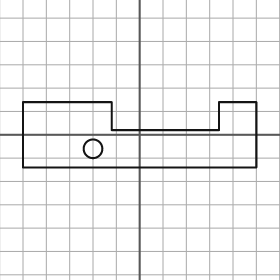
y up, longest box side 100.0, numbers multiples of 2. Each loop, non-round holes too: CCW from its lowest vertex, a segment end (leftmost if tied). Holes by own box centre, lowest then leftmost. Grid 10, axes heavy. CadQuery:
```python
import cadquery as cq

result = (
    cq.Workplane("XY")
    .moveTo(-50.0, -14.0)
    .lineTo(50.0, -14.0)
    .lineTo(50.0, 14.0)
    .lineTo(34.0, 14.0)
    .lineTo(34.0, 2.0)
    .lineTo(-12.0, 2.0)
    .lineTo(-12.0, 14.0)
    .lineTo(-50.0, 14.0)
    .close()
    .moveTo(-20.0, -6.0)
    .circle(4.0)
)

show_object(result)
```